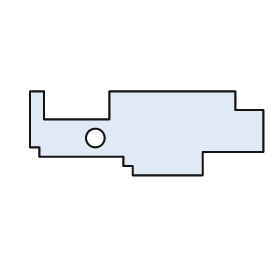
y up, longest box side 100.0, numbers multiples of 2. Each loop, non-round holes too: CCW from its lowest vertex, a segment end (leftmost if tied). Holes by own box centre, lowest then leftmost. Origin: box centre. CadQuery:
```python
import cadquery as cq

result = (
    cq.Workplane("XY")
    .moveTo(-6.0, -18.0)
    .lineTo(24.0, -18.0)
    .lineTo(24.0, -8.0)
    .lineTo(50.0, -8.0)
    .lineTo(50.0, 10.0)
    .lineTo(38.0, 10.0)
    .lineTo(38.0, 18.0)
    .lineTo(-16.0, 18.0)
    .lineTo(-16.0, 6.0)
    .lineTo(-44.0, 6.0)
    .lineTo(-44.0, 18.0)
    .lineTo(-50.0, 18.0)
    .lineTo(-50.0, -6.0)
    .lineTo(-46.0, -6.0)
    .lineTo(-46.0, -10.0)
    .lineTo(-10.0, -10.0)
    .lineTo(-10.0, -14.0)
    .lineTo(-6.0, -14.0)
    .close()
    .moveTo(-22.0, -2.0)
    .circle(4.0)
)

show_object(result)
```